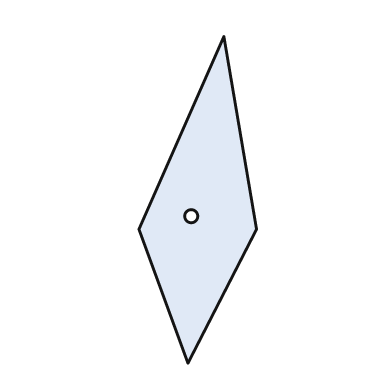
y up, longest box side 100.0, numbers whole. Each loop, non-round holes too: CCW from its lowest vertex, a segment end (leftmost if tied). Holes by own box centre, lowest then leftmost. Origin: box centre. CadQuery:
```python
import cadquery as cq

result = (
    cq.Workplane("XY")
    .moveTo(-3.0, -50.0)
    .lineTo(18.0, -9.0)
    .lineTo(8.0, 50.0)
    .lineTo(-18.0, -9.0)
    .close()
    .moveTo(-2.0, -5.0)
    .circle(2.0)
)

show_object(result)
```